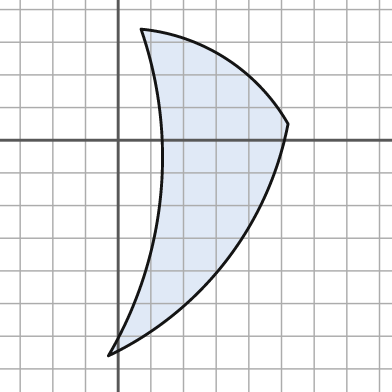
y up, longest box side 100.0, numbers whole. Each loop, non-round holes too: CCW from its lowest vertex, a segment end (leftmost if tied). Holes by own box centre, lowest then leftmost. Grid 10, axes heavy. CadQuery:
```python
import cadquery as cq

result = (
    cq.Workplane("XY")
    .moveTo(-3.0, -66.0)
    .threePointArc((33.0, -37.0), (52.0, 5.0))
    .threePointArc((33.0, 25.0), (7.0, 34.0))
    .threePointArc((13.0, -17.0), (-3.0, -66.0))
    .close()
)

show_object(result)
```